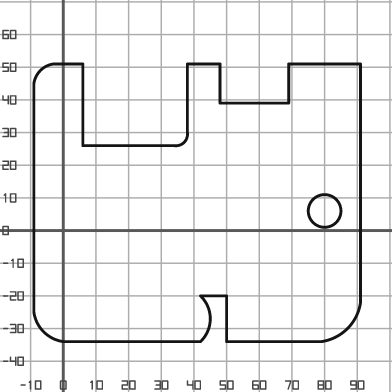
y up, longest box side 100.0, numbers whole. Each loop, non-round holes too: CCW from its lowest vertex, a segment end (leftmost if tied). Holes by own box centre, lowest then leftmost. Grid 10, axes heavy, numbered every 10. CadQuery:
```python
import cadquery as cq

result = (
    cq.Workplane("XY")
    .moveTo(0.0, -34.0)
    .lineTo(42.0, -34.0)
    .threePointArc((45.0, -27.0), (42.0, -20.0))
    .lineTo(50.0, -20.0)
    .lineTo(50.0, -34.0)
    .lineTo(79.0, -34.0)
    .threePointArc((87.0, -30.0), (91.0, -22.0))
    .lineTo(91.0, 51.0)
    .lineTo(69.0, 51.0)
    .lineTo(69.0, 39.0)
    .lineTo(48.0, 39.0)
    .lineTo(48.0, 51.0)
    .lineTo(38.0, 51.0)
    .lineTo(38.0, 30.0)
    .threePointArc((37.0, 27.0), (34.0, 26.0))
    .lineTo(6.0, 26.0)
    .lineTo(6.0, 51.0)
    .lineTo(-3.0, 51.0)
    .threePointArc((-7.0, 49.0), (-9.0, 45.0))
    .lineTo(-9.0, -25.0)
    .threePointArc((-6.0, -31.0), (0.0, -34.0))
    .close()
    .moveTo(80.0, 6.0)
    .circle(5.0)
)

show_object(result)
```